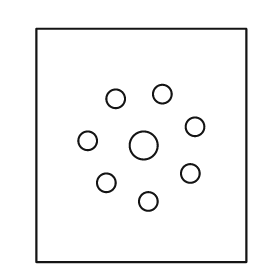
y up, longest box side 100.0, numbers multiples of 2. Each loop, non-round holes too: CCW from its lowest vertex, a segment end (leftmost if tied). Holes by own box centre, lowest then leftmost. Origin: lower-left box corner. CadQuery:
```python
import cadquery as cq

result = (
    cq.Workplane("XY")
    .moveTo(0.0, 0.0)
    .lineTo(90.0, 0.0)
    .lineTo(90.0, 100.0)
    .lineTo(0.0, 100.0)
    .close()
    .moveTo(48.0, 26.0)
    .circle(4.0)
    .moveTo(30.0, 34.0)
    .circle(4.0)
    .moveTo(66.0, 38.0)
    .circle(4.0)
    .moveTo(46.0, 50.0)
    .circle(6.0)
    .moveTo(22.0, 52.0)
    .circle(4.0)
    .moveTo(68.0, 58.0)
    .circle(4.0)
    .moveTo(34.0, 70.0)
    .circle(4.0)
    .moveTo(54.0, 72.0)
    .circle(4.0)
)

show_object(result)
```